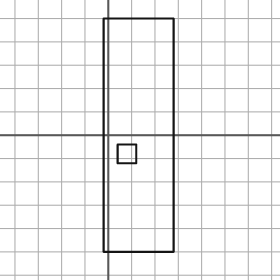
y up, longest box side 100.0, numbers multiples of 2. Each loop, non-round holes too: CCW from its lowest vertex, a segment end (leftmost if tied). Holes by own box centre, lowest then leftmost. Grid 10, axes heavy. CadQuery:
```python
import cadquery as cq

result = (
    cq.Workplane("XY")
    .moveTo(-2.0, -50.0)
    .lineTo(28.0, -50.0)
    .lineTo(28.0, 50.0)
    .lineTo(-2.0, 50.0)
    .close()
    .moveTo(4.0, -12.0)
    .lineTo(12.0, -12.0)
    .lineTo(12.0, -4.0)
    .lineTo(4.0, -4.0)
    .close()
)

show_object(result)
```